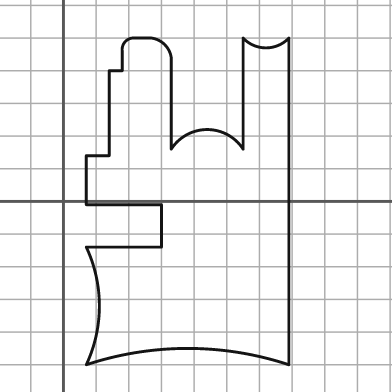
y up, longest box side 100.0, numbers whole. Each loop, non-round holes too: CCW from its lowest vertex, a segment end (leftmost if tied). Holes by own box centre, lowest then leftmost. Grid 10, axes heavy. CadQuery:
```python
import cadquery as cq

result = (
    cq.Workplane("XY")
    .moveTo(7.0, -50.0)
    .threePointArc((38.0, -45.0), (69.0, -50.0))
    .lineTo(69.0, 50.0)
    .threePointArc((62.0, 47.0), (55.0, 50.0))
    .lineTo(55.0, 16.0)
    .threePointArc((44.0, 22.0), (33.0, 16.0))
    .lineTo(33.0, 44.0)
    .threePointArc((31.0, 48.0), (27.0, 50.0))
    .lineTo(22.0, 50.0)
    .threePointArc((19.0, 49.0), (18.0, 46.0))
    .lineTo(18.0, 40.0)
    .lineTo(14.0, 40.0)
    .lineTo(14.0, 14.0)
    .lineTo(7.0, 14.0)
    .lineTo(7.0, -1.0)
    .lineTo(30.0, -1.0)
    .lineTo(30.0, -14.0)
    .lineTo(7.0, -14.0)
    .threePointArc((11.0, -32.0), (7.0, -50.0))
    .close()
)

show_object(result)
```